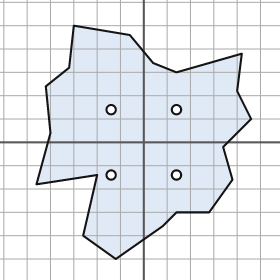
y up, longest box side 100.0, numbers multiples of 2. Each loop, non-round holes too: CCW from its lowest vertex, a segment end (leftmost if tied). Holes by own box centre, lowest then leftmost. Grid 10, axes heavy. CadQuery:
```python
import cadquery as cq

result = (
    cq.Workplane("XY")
    .moveTo(-12.0, -50.0)
    .lineTo(8.0, -36.0)
    .lineTo(14.0, -30.0)
    .lineTo(28.0, -30.0)
    .lineTo(38.0, -16.0)
    .lineTo(34.0, -2.0)
    .lineTo(46.0, 10.0)
    .lineTo(40.0, 22.0)
    .lineTo(42.0, 38.0)
    .lineTo(14.0, 30.0)
    .lineTo(4.0, 34.0)
    .lineTo(-6.0, 46.0)
    .lineTo(-30.0, 50.0)
    .lineTo(-32.0, 32.0)
    .lineTo(-42.0, 24.0)
    .lineTo(-40.0, 4.0)
    .lineTo(-46.0, -18.0)
    .lineTo(-20.0, -14.0)
    .lineTo(-26.0, -40.0)
    .close()
    .moveTo(-14.0, -14.0)
    .circle(2.0)
    .moveTo(14.0, -14.0)
    .circle(2.0)
    .moveTo(-14.0, 14.0)
    .circle(2.0)
    .moveTo(14.0, 14.0)
    .circle(2.0)
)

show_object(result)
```